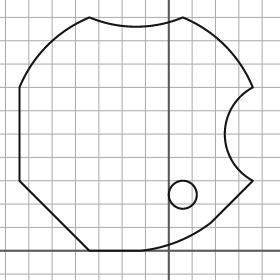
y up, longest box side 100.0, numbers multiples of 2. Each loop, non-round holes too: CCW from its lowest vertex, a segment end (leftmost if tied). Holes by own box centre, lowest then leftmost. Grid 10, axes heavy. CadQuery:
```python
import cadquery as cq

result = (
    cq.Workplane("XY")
    .moveTo(-34.0, 0.0)
    .lineTo(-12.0, 0.0)
    .threePointArc((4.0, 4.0), (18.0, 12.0))
    .lineTo(36.0, 30.0)
    .threePointArc((24.0, 50.0), (36.0, 70.0))
    .threePointArc((24.0, 88.0), (6.0, 100.0))
    .threePointArc((-14.0, 96.0), (-34.0, 100.0))
    .threePointArc((-52.0, 88.0), (-64.0, 70.0))
    .lineTo(-64.0, 30.0)
    .close()
    .moveTo(6.0, 24.0)
    .circle(6.0)
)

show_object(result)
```